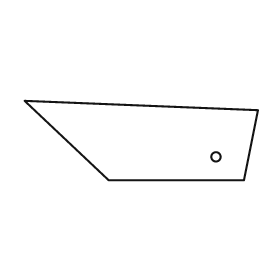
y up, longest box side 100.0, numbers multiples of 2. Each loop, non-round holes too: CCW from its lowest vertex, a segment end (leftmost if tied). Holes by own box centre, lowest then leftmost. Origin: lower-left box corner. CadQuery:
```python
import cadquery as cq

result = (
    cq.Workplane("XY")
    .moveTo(36.0, 0.0)
    .lineTo(94.0, 0.0)
    .lineTo(100.0, 30.0)
    .lineTo(0.0, 34.0)
    .close()
    .moveTo(82.0, 10.0)
    .circle(2.0)
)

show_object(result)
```